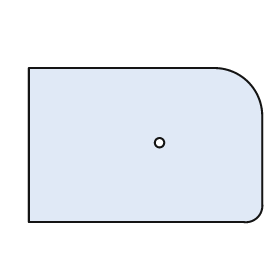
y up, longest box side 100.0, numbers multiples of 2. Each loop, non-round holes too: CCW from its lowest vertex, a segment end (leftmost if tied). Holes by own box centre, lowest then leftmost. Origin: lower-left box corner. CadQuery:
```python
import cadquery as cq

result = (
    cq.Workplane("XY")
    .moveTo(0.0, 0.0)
    .lineTo(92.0, 0.0)
    .threePointArc((98.0, 2.0), (100.0, 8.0))
    .lineTo(100.0, 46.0)
    .threePointArc((94.0, 60.0), (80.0, 66.0))
    .lineTo(0.0, 66.0)
    .close()
    .moveTo(56.0, 34.0)
    .circle(2.0)
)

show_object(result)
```